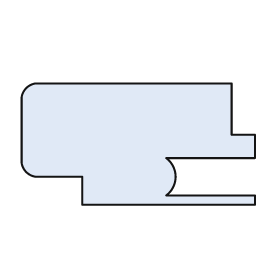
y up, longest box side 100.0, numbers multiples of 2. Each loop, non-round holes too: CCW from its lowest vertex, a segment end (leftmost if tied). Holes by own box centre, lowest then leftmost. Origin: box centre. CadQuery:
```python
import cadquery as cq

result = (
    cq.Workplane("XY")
    .moveTo(-24.0, -26.0)
    .lineTo(50.0, -26.0)
    .lineTo(50.0, -22.0)
    .lineTo(12.0, -22.0)
    .threePointArc((16.0, -14.0), (12.0, -6.0))
    .lineTo(50.0, -6.0)
    .lineTo(50.0, 4.0)
    .lineTo(40.0, 4.0)
    .lineTo(40.0, 26.0)
    .lineTo(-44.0, 26.0)
    .threePointArc((-48.0, 24.0), (-50.0, 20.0))
    .lineTo(-50.0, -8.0)
    .threePointArc((-48.0, -12.0), (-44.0, -14.0))
    .lineTo(-24.0, -14.0)
    .close()
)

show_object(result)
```